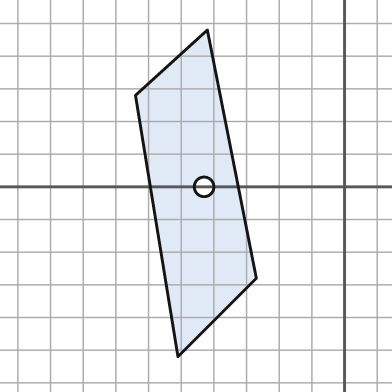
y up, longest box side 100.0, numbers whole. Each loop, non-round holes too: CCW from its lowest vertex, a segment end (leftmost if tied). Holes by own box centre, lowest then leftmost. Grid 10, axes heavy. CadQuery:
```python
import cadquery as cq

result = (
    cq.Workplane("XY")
    .moveTo(-51.0, -52.0)
    .lineTo(-27.0, -28.0)
    .lineTo(-42.0, 48.0)
    .lineTo(-64.0, 28.0)
    .close()
    .moveTo(-43.0, 0.0)
    .circle(3.0)
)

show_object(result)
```